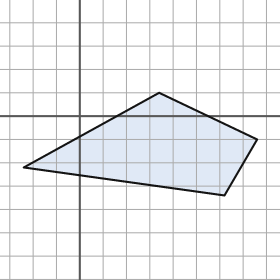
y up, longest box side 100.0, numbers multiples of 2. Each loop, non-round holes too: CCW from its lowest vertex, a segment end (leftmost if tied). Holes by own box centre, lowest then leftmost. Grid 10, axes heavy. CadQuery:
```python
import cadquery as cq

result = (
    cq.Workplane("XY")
    .moveTo(62.0, -34.0)
    .lineTo(76.0, -10.0)
    .lineTo(34.0, 10.0)
    .lineTo(-24.0, -22.0)
    .close()
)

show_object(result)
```